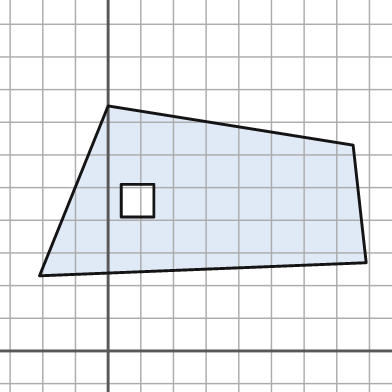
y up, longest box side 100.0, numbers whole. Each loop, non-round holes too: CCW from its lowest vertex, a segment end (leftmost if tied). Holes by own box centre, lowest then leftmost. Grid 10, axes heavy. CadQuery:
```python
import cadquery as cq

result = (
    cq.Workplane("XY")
    .moveTo(-21.0, 23.0)
    .lineTo(79.0, 27.0)
    .lineTo(75.0, 63.0)
    .lineTo(0.0, 75.0)
    .close()
    .moveTo(4.0, 41.0)
    .lineTo(14.0, 41.0)
    .lineTo(14.0, 51.0)
    .lineTo(4.0, 51.0)
    .close()
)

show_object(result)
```